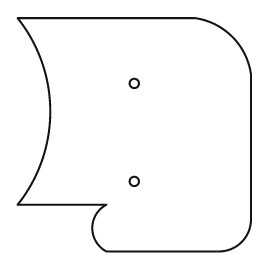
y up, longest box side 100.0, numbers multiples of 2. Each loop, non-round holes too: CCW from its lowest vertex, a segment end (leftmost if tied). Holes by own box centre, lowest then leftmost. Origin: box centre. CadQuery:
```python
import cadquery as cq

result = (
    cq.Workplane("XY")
    .moveTo(-12.0, -50.0)
    .lineTo(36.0, -50.0)
    .threePointArc((46.0, -46.0), (50.0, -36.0))
    .lineTo(50.0, 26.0)
    .threePointArc((42.0, 42.0), (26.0, 50.0))
    .lineTo(-50.0, 50.0)
    .threePointArc((-36.0, 10.0), (-50.0, -30.0))
    .lineTo(-12.0, -30.0)
    .threePointArc((-18.0, -40.0), (-12.0, -50.0))
    .close()
    .moveTo(0.0, -20.0)
    .circle(2.0)
    .moveTo(0.0, 22.0)
    .circle(2.0)
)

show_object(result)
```